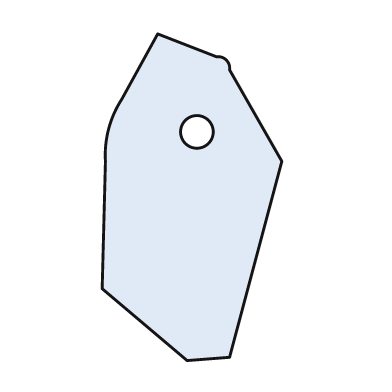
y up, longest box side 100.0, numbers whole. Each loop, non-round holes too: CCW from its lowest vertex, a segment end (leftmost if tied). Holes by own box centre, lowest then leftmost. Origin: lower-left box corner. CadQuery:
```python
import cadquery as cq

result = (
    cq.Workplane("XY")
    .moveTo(26.0, 0.0)
    .lineTo(39.0, 1.0)
    .lineTo(55.0, 61.0)
    .lineTo(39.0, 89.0)
    .threePointArc((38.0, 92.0), (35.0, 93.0))
    .lineTo(17.0, 100.0)
    .lineTo(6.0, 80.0)
    .threePointArc((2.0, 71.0), (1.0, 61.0))
    .lineTo(0.0, 22.0)
    .close()
    .moveTo(29.0, 70.0)
    .circle(5.0)
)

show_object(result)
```